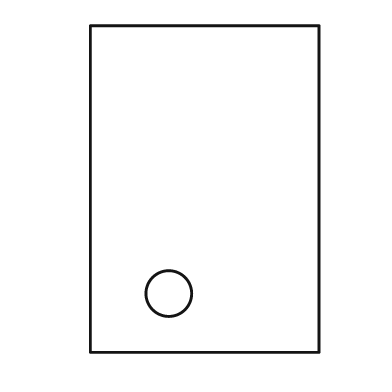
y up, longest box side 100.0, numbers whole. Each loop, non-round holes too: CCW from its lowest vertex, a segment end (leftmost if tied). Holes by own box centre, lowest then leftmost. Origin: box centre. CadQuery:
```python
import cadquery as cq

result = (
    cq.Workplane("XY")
    .moveTo(-35.0, -50.0)
    .lineTo(35.0, -50.0)
    .lineTo(35.0, 50.0)
    .lineTo(-35.0, 50.0)
    .close()
    .moveTo(-11.0, -32.0)
    .circle(7.0)
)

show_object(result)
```